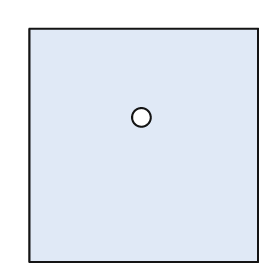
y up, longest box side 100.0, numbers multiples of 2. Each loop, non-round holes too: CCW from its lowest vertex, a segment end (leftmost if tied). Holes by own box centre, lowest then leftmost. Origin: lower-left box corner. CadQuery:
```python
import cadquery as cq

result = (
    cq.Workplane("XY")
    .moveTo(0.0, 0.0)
    .lineTo(98.0, 0.0)
    .lineTo(98.0, 100.0)
    .lineTo(0.0, 100.0)
    .close()
    .moveTo(48.0, 62.0)
    .circle(4.0)
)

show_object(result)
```